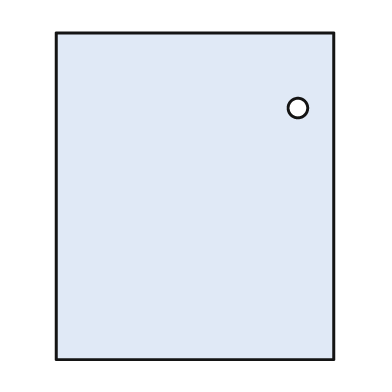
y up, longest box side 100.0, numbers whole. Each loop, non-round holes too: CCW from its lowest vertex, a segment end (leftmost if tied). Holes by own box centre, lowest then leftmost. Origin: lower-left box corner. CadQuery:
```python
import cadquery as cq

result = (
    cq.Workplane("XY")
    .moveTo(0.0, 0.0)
    .lineTo(85.0, 0.0)
    .lineTo(85.0, 100.0)
    .lineTo(0.0, 100.0)
    .close()
    .moveTo(74.0, 77.0)
    .circle(3.0)
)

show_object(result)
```